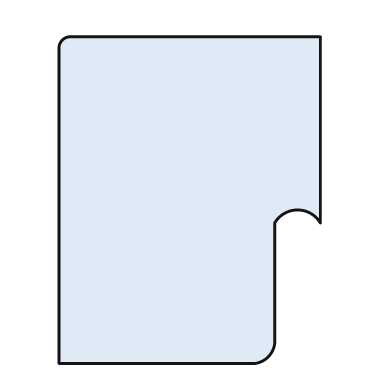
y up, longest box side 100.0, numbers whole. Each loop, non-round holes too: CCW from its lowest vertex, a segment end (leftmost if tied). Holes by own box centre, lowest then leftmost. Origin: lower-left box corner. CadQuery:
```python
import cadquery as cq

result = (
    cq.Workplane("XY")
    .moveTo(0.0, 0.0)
    .lineTo(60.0, 0.0)
    .threePointArc((64.0, 2.0), (66.0, 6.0))
    .lineTo(66.0, 43.0)
    .threePointArc((73.0, 47.0), (80.0, 43.0))
    .lineTo(80.0, 100.0)
    .lineTo(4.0, 100.0)
    .threePointArc((1.0, 99.0), (0.0, 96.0))
    .close()
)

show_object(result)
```